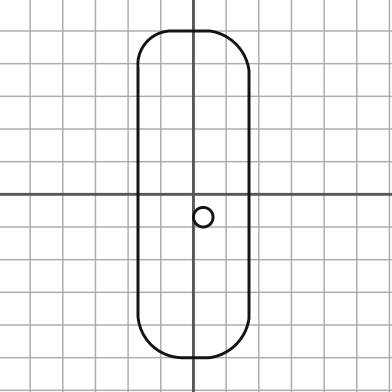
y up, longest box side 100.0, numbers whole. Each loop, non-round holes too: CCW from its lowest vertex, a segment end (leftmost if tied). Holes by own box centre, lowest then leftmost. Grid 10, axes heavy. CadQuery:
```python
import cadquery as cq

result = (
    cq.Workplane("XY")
    .moveTo(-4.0, -50.0)
    .lineTo(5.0, -50.0)
    .threePointArc((13.0, -46.0), (17.0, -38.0))
    .lineTo(17.0, 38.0)
    .threePointArc((13.0, 46.0), (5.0, 50.0))
    .lineTo(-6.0, 50.0)
    .threePointArc((-14.0, 47.0), (-17.0, 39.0))
    .lineTo(-17.0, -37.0)
    .threePointArc((-13.0, -46.0), (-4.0, -50.0))
    .close()
    .moveTo(3.0, -7.0)
    .circle(3.0)
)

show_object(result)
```